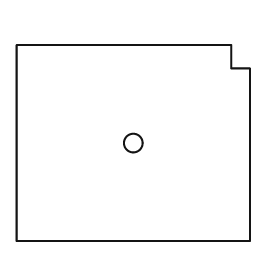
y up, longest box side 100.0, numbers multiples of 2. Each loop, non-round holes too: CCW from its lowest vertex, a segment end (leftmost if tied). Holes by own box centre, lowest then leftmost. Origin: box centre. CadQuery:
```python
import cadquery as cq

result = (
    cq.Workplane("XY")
    .moveTo(-50.0, -42.0)
    .lineTo(50.0, -42.0)
    .lineTo(50.0, 32.0)
    .lineTo(42.0, 32.0)
    .lineTo(42.0, 42.0)
    .lineTo(-50.0, 42.0)
    .close()
    .moveTo(0.0, 0.0)
    .circle(4.0)
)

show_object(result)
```